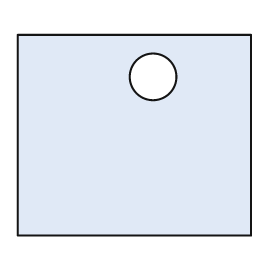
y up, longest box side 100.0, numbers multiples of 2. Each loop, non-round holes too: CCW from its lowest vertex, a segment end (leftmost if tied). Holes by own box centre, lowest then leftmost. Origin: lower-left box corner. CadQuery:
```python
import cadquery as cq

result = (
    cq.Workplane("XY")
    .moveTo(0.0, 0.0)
    .lineTo(100.0, 0.0)
    .lineTo(100.0, 86.0)
    .lineTo(0.0, 86.0)
    .close()
    .moveTo(58.0, 68.0)
    .circle(10.0)
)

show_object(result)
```